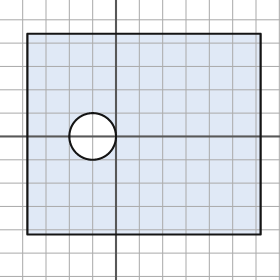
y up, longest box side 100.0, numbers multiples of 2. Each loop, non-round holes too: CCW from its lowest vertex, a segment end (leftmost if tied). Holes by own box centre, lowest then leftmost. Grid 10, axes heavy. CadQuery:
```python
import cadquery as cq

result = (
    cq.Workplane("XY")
    .moveTo(-38.0, -42.0)
    .lineTo(62.0, -42.0)
    .lineTo(62.0, 44.0)
    .lineTo(-38.0, 44.0)
    .close()
    .moveTo(-10.0, 0.0)
    .circle(10.0)
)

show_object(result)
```